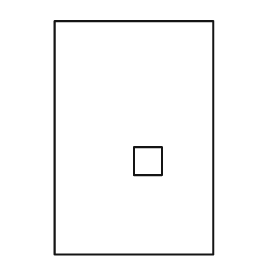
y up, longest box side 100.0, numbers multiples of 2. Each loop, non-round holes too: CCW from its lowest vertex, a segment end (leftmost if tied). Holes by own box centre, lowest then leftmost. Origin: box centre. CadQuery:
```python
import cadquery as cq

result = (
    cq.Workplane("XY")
    .moveTo(-34.0, -50.0)
    .lineTo(34.0, -50.0)
    .lineTo(34.0, 50.0)
    .lineTo(-34.0, 50.0)
    .close()
    .moveTo(0.0, -16.0)
    .lineTo(12.0, -16.0)
    .lineTo(12.0, -4.0)
    .lineTo(0.0, -4.0)
    .close()
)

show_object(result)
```